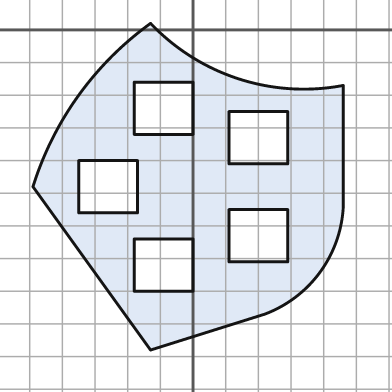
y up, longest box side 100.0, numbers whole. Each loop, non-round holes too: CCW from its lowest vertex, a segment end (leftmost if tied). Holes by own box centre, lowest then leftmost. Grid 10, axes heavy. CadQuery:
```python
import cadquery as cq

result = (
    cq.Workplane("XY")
    .moveTo(-13.0, -98.0)
    .lineTo(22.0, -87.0)
    .threePointArc((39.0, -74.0), (46.0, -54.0))
    .lineTo(46.0, -17.0)
    .threePointArc((14.0, -15.0), (-13.0, 2.0))
    .threePointArc((-35.0, -20.0), (-49.0, -48.0))
    .close()
    .moveTo(-18.0, -80.0)
    .lineTo(0.0, -80.0)
    .lineTo(0.0, -64.0)
    .lineTo(-18.0, -64.0)
    .close()
    .moveTo(11.0, -71.0)
    .lineTo(29.0, -71.0)
    .lineTo(29.0, -55.0)
    .lineTo(11.0, -55.0)
    .close()
    .moveTo(-35.0, -56.0)
    .lineTo(-17.0, -56.0)
    .lineTo(-17.0, -40.0)
    .lineTo(-35.0, -40.0)
    .close()
    .moveTo(11.0, -41.0)
    .lineTo(29.0, -41.0)
    .lineTo(29.0, -25.0)
    .lineTo(11.0, -25.0)
    .close()
    .moveTo(-18.0, -32.0)
    .lineTo(0.0, -32.0)
    .lineTo(0.0, -16.0)
    .lineTo(-18.0, -16.0)
    .close()
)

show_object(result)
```